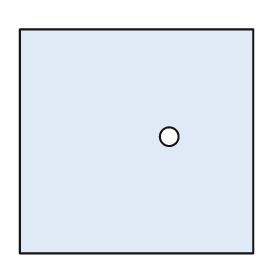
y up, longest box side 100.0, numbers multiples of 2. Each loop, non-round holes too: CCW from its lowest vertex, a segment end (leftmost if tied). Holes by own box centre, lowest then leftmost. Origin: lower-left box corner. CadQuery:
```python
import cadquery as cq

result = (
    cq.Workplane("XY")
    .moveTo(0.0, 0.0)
    .lineTo(100.0, 0.0)
    .lineTo(100.0, 96.0)
    .lineTo(0.0, 96.0)
    .close()
    .moveTo(64.0, 50.0)
    .circle(4.0)
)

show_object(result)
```